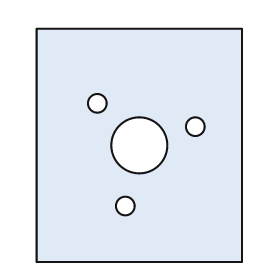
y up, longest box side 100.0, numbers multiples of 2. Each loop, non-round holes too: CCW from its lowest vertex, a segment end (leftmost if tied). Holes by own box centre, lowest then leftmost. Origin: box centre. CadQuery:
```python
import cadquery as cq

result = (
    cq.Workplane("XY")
    .moveTo(-44.0, -50.0)
    .lineTo(44.0, -50.0)
    .lineTo(44.0, 50.0)
    .lineTo(-44.0, 50.0)
    .close()
    .moveTo(-6.0, -26.0)
    .circle(4.0)
    .moveTo(0.0, 0.0)
    .circle(12.0)
    .moveTo(24.0, 8.0)
    .circle(4.0)
    .moveTo(-18.0, 18.0)
    .circle(4.0)
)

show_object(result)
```